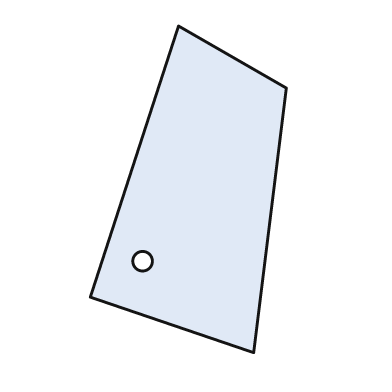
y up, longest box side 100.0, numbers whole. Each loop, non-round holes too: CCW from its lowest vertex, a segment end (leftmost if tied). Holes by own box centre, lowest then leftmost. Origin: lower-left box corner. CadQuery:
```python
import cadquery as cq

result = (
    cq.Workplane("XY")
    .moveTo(50.0, 0.0)
    .lineTo(60.0, 81.0)
    .lineTo(27.0, 100.0)
    .lineTo(0.0, 17.0)
    .close()
    .moveTo(16.0, 28.0)
    .circle(3.0)
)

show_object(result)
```